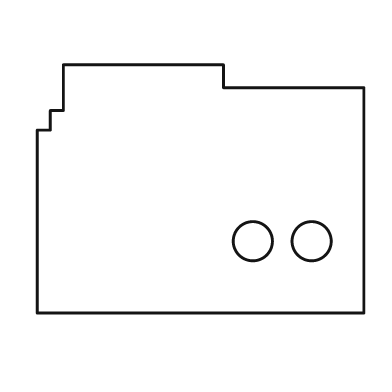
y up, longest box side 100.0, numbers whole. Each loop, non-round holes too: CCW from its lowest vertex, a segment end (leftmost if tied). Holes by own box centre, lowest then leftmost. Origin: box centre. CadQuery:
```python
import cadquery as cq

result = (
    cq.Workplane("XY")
    .moveTo(-50.0, -38.0)
    .lineTo(50.0, -38.0)
    .lineTo(50.0, 31.0)
    .lineTo(7.0, 31.0)
    .lineTo(7.0, 38.0)
    .lineTo(-42.0, 38.0)
    .lineTo(-42.0, 24.0)
    .lineTo(-46.0, 24.0)
    .lineTo(-46.0, 18.0)
    .lineTo(-50.0, 18.0)
    .close()
    .moveTo(16.0, -16.0)
    .circle(6.0)
    .moveTo(34.0, -16.0)
    .circle(6.0)
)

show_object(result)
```